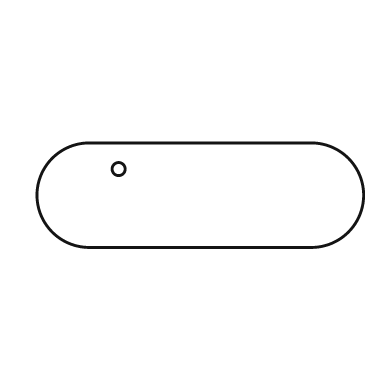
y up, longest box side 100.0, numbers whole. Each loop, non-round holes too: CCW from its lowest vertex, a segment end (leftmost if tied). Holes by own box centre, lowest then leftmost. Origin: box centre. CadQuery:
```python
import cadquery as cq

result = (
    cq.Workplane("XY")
    .moveTo(-34.0, -16.0)
    .lineTo(34.0, -16.0)
    .threePointArc((50.0, 0.0), (34.0, 16.0))
    .lineTo(-34.0, 16.0)
    .threePointArc((-50.0, 0.0), (-34.0, -16.0))
    .close()
    .moveTo(-25.0, 8.0)
    .circle(2.0)
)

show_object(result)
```